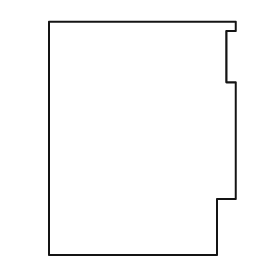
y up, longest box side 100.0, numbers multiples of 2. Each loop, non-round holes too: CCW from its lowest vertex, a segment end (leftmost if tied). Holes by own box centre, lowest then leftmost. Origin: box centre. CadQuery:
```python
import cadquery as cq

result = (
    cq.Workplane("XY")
    .moveTo(-40.0, -50.0)
    .lineTo(32.0, -50.0)
    .lineTo(32.0, -26.0)
    .lineTo(40.0, -26.0)
    .lineTo(40.0, 24.0)
    .lineTo(36.0, 24.0)
    .lineTo(36.0, 46.0)
    .lineTo(40.0, 46.0)
    .lineTo(40.0, 50.0)
    .lineTo(-40.0, 50.0)
    .close()
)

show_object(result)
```